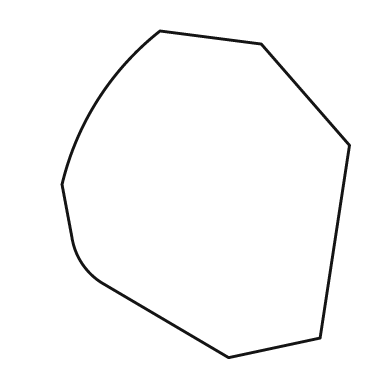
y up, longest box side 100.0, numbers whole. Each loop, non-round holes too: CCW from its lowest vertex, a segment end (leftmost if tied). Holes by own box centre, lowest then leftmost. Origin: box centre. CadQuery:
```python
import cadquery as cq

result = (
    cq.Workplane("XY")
    .moveTo(7.0, -50.0)
    .lineTo(35.0, -44.0)
    .lineTo(44.0, 15.0)
    .lineTo(17.0, 46.0)
    .lineTo(-14.0, 50.0)
    .threePointArc((-33.0, 29.0), (-44.0, 3.0))
    .lineTo(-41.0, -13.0)
    .threePointArc((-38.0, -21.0), (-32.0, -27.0))
    .close()
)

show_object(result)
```